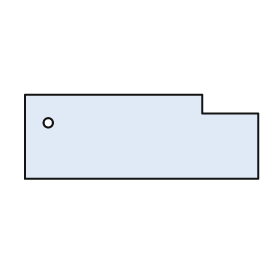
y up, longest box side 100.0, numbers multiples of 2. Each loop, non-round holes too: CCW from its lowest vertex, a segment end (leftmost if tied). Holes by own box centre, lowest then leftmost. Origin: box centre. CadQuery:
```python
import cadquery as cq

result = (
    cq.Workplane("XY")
    .moveTo(-50.0, -18.0)
    .lineTo(50.0, -18.0)
    .lineTo(50.0, 10.0)
    .lineTo(26.0, 10.0)
    .lineTo(26.0, 18.0)
    .lineTo(-50.0, 18.0)
    .close()
    .moveTo(-40.0, 6.0)
    .circle(2.0)
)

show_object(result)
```